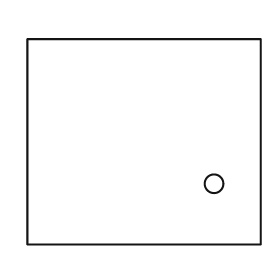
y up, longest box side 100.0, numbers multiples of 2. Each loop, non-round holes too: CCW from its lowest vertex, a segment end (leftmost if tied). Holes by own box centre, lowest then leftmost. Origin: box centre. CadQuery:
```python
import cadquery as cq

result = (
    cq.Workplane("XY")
    .moveTo(-50.0, -44.0)
    .lineTo(50.0, -44.0)
    .lineTo(50.0, 44.0)
    .lineTo(-50.0, 44.0)
    .close()
    .moveTo(30.0, -18.0)
    .circle(4.0)
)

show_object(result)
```